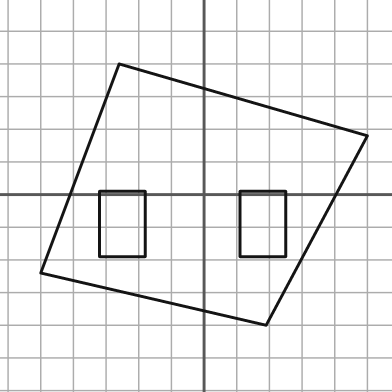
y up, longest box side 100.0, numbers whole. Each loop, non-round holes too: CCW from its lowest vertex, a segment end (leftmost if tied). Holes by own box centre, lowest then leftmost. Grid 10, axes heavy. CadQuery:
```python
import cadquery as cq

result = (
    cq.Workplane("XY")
    .moveTo(19.0, -40.0)
    .lineTo(50.0, 18.0)
    .lineTo(-26.0, 40.0)
    .lineTo(-50.0, -24.0)
    .close()
    .moveTo(-32.0, -19.0)
    .lineTo(-18.0, -19.0)
    .lineTo(-18.0, 1.0)
    .lineTo(-32.0, 1.0)
    .close()
    .moveTo(11.0, -19.0)
    .lineTo(25.0, -19.0)
    .lineTo(25.0, 1.0)
    .lineTo(11.0, 1.0)
    .close()
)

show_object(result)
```